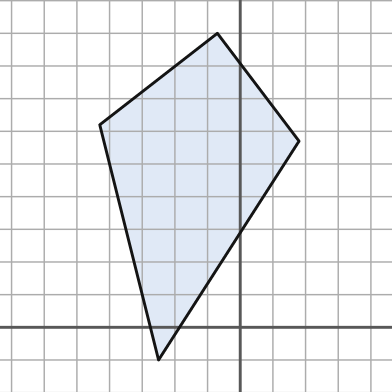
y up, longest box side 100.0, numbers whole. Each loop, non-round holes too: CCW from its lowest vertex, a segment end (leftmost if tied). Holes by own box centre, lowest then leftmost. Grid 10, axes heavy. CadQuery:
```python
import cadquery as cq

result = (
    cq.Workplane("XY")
    .moveTo(-25.0, -10.0)
    .lineTo(18.0, 57.0)
    .lineTo(-7.0, 90.0)
    .lineTo(-43.0, 62.0)
    .close()
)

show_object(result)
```